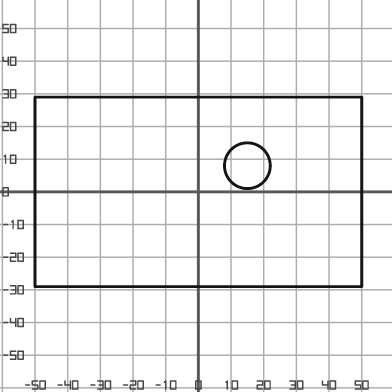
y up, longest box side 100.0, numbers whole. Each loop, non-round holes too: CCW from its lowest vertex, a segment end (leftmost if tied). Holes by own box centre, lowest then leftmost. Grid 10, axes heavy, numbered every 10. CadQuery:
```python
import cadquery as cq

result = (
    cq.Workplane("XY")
    .moveTo(-50.0, -29.0)
    .lineTo(50.0, -29.0)
    .lineTo(50.0, 29.0)
    .lineTo(-50.0, 29.0)
    .close()
    .moveTo(15.0, 8.0)
    .circle(7.0)
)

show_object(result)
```